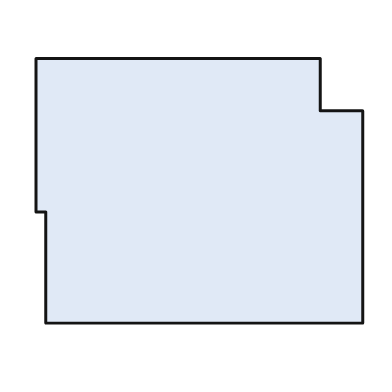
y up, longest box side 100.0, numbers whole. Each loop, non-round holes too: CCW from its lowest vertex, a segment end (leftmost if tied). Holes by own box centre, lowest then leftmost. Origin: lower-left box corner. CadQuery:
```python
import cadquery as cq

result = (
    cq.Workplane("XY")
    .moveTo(3.0, 0.0)
    .lineTo(100.0, 0.0)
    .lineTo(100.0, 65.0)
    .lineTo(87.0, 65.0)
    .lineTo(87.0, 81.0)
    .lineTo(0.0, 81.0)
    .lineTo(0.0, 34.0)
    .lineTo(3.0, 34.0)
    .close()
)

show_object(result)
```